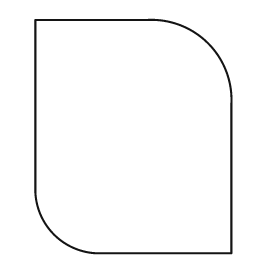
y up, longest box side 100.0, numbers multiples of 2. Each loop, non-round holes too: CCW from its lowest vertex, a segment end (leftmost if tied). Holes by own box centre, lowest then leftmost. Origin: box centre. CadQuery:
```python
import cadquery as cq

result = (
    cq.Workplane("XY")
    .moveTo(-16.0, -50.0)
    .lineTo(42.0, -50.0)
    .lineTo(42.0, 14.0)
    .threePointArc((32.0, 40.0), (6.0, 50.0))
    .lineTo(-42.0, 50.0)
    .lineTo(-42.0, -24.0)
    .threePointArc((-34.0, -42.0), (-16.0, -50.0))
    .close()
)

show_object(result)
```